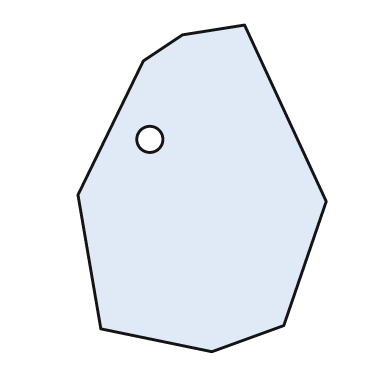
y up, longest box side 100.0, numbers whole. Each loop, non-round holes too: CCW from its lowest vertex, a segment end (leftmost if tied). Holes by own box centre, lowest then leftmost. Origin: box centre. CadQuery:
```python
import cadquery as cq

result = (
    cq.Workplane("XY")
    .moveTo(3.0, -50.0)
    .lineTo(25.0, -42.0)
    .lineTo(38.0, -4.0)
    .lineTo(13.0, 50.0)
    .lineTo(-6.0, 47.0)
    .lineTo(-18.0, 39.0)
    .lineTo(-38.0, -2.0)
    .lineTo(-31.0, -43.0)
    .close()
    .moveTo(-16.0, 15.0)
    .circle(4.0)
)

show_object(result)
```